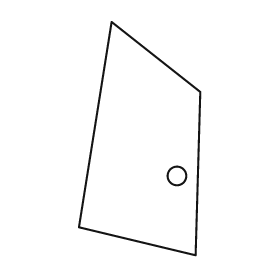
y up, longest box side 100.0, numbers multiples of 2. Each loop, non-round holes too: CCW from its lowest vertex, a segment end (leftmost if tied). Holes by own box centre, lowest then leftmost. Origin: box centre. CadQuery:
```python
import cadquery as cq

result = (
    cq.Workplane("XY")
    .moveTo(24.0, -50.0)
    .lineTo(26.0, 20.0)
    .lineTo(-12.0, 50.0)
    .lineTo(-26.0, -38.0)
    .close()
    .moveTo(16.0, -16.0)
    .circle(4.0)
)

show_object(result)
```